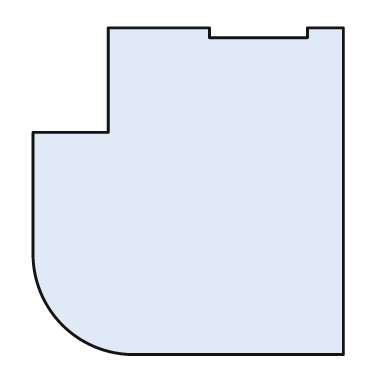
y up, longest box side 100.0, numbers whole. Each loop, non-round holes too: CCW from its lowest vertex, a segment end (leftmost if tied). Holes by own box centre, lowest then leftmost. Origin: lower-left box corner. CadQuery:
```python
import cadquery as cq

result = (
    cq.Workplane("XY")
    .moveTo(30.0, 0.0)
    .lineTo(95.0, 0.0)
    .lineTo(95.0, 100.0)
    .lineTo(84.0, 100.0)
    .lineTo(84.0, 97.0)
    .lineTo(54.0, 97.0)
    .lineTo(54.0, 100.0)
    .lineTo(23.0, 100.0)
    .lineTo(23.0, 68.0)
    .lineTo(0.0, 68.0)
    .lineTo(0.0, 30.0)
    .threePointArc((9.0, 9.0), (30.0, 0.0))
    .close()
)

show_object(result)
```